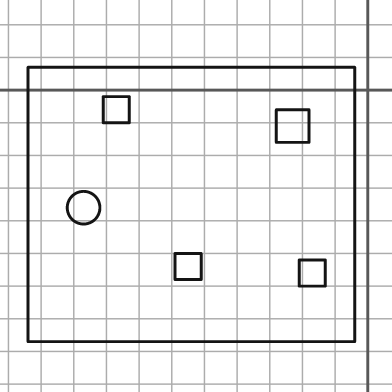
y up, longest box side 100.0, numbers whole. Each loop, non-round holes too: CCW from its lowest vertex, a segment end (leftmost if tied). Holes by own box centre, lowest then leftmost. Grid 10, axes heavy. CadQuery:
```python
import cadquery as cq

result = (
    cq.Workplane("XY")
    .moveTo(-104.0, -77.0)
    .lineTo(-4.0, -77.0)
    .lineTo(-4.0, 7.0)
    .lineTo(-104.0, 7.0)
    .close()
    .moveTo(-21.0, -60.0)
    .lineTo(-13.0, -60.0)
    .lineTo(-13.0, -52.0)
    .lineTo(-21.0, -52.0)
    .close()
    .moveTo(-59.0, -58.0)
    .lineTo(-51.0, -58.0)
    .lineTo(-51.0, -50.0)
    .lineTo(-59.0, -50.0)
    .close()
    .moveTo(-87.0, -36.0)
    .circle(5.0)
    .moveTo(-28.0, -16.0)
    .lineTo(-18.0, -16.0)
    .lineTo(-18.0, -6.0)
    .lineTo(-28.0, -6.0)
    .close()
    .moveTo(-81.0, -10.0)
    .lineTo(-73.0, -10.0)
    .lineTo(-73.0, -2.0)
    .lineTo(-81.0, -2.0)
    .close()
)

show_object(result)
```